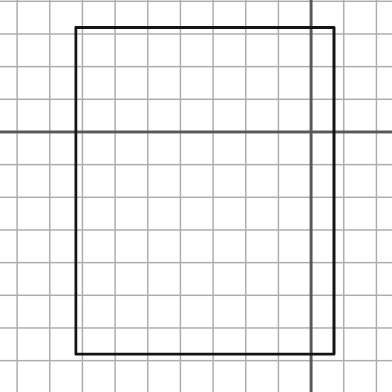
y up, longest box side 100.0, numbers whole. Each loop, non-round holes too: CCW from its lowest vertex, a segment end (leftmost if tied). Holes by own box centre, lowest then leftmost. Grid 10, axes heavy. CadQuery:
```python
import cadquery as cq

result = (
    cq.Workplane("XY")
    .moveTo(-72.0, -68.0)
    .lineTo(7.0, -68.0)
    .lineTo(7.0, 32.0)
    .lineTo(-72.0, 32.0)
    .close()
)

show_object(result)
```